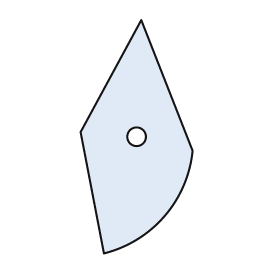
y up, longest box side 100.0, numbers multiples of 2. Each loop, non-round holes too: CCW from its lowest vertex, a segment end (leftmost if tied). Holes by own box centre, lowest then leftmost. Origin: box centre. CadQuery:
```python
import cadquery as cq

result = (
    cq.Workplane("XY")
    .moveTo(-14.0, -50.0)
    .threePointArc((12.0, -34.0), (24.0, -6.0))
    .lineTo(2.0, 50.0)
    .lineTo(-24.0, 2.0)
    .close()
    .moveTo(0.0, 0.0)
    .circle(4.0)
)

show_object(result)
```